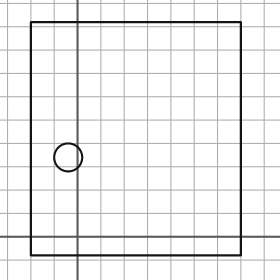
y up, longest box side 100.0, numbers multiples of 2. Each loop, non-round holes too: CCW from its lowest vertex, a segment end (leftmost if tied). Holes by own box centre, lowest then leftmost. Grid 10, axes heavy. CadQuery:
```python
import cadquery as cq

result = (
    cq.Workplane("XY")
    .moveTo(-20.0, -8.0)
    .lineTo(70.0, -8.0)
    .lineTo(70.0, 92.0)
    .lineTo(-20.0, 92.0)
    .close()
    .moveTo(-4.0, 34.0)
    .circle(6.0)
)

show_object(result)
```